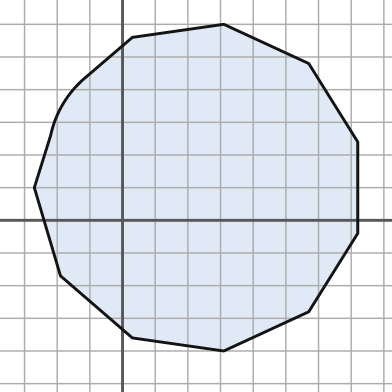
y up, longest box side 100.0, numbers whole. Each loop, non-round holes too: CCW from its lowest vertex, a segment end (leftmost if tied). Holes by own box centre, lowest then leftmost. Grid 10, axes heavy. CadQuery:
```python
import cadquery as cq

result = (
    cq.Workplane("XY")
    .moveTo(31.0, -40.0)
    .lineTo(57.0, -28.0)
    .lineTo(72.0, -4.0)
    .lineTo(72.0, 24.0)
    .lineTo(57.0, 48.0)
    .lineTo(31.0, 60.0)
    .lineTo(3.0, 56.0)
    .lineTo(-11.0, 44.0)
    .threePointArc((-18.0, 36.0), (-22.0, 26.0))
    .lineTo(-27.0, 10.0)
    .lineTo(-19.0, -17.0)
    .lineTo(3.0, -36.0)
    .close()
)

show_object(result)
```